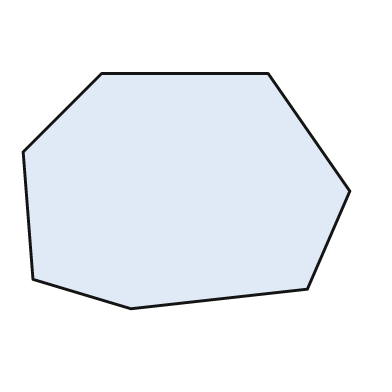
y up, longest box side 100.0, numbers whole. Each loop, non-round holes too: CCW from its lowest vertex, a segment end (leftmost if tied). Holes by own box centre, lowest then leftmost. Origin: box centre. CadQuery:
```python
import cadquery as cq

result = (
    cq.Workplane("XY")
    .moveTo(-17.0, -36.0)
    .lineTo(37.0, -30.0)
    .lineTo(50.0, 0.0)
    .lineTo(25.0, 36.0)
    .lineTo(-26.0, 36.0)
    .lineTo(-50.0, 12.0)
    .lineTo(-47.0, -27.0)
    .close()
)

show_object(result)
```